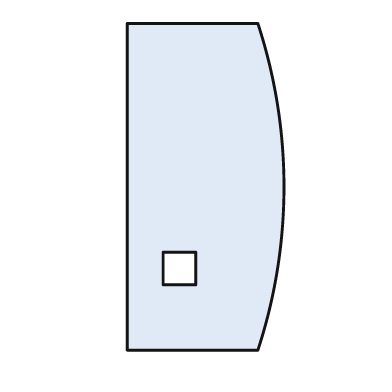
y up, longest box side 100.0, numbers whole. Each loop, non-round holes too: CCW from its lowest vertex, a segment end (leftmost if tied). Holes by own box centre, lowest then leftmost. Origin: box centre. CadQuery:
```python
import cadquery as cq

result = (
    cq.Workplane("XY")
    .moveTo(-24.0, -50.0)
    .lineTo(16.0, -50.0)
    .threePointArc((24.0, 0.0), (16.0, 50.0))
    .lineTo(-24.0, 50.0)
    .close()
    .moveTo(-13.0, -30.0)
    .lineTo(-3.0, -30.0)
    .lineTo(-3.0, -20.0)
    .lineTo(-13.0, -20.0)
    .close()
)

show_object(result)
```